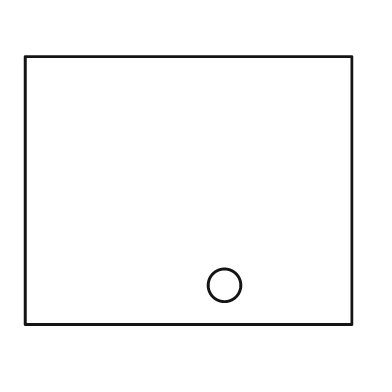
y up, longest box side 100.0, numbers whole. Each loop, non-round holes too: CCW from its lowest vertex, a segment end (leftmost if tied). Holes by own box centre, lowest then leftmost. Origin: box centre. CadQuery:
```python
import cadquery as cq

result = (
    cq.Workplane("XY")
    .moveTo(-50.0, -41.0)
    .lineTo(50.0, -41.0)
    .lineTo(50.0, 41.0)
    .lineTo(-50.0, 41.0)
    .close()
    .moveTo(11.0, -29.0)
    .circle(5.0)
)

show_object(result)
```